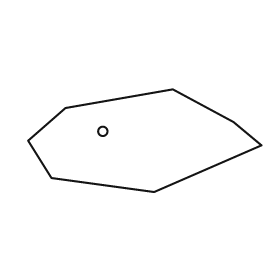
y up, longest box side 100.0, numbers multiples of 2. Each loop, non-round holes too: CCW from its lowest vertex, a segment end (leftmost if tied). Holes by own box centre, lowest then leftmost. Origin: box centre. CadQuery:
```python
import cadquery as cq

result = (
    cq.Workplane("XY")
    .moveTo(4.0, -22.0)
    .lineTo(50.0, -2.0)
    .lineTo(38.0, 8.0)
    .lineTo(12.0, 22.0)
    .lineTo(-34.0, 14.0)
    .lineTo(-50.0, 0.0)
    .lineTo(-40.0, -16.0)
    .close()
    .moveTo(-18.0, 4.0)
    .circle(2.0)
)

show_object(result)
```